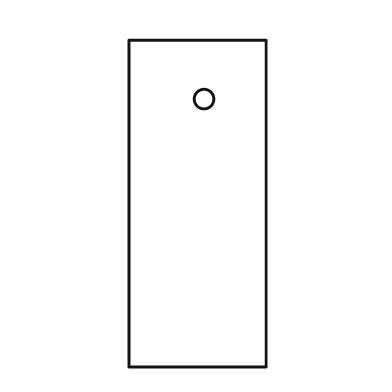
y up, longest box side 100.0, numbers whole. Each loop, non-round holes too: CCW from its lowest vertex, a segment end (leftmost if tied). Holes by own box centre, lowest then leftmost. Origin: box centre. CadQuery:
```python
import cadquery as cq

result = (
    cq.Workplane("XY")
    .moveTo(-21.0, -50.0)
    .lineTo(21.0, -50.0)
    .lineTo(21.0, 50.0)
    .lineTo(-21.0, 50.0)
    .close()
    .moveTo(2.0, 32.0)
    .circle(3.0)
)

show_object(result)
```